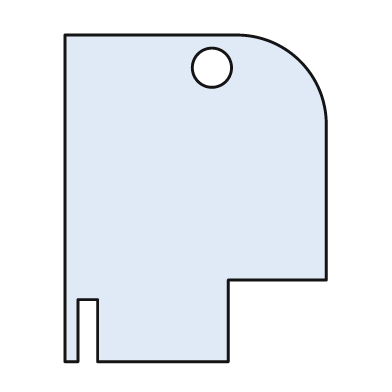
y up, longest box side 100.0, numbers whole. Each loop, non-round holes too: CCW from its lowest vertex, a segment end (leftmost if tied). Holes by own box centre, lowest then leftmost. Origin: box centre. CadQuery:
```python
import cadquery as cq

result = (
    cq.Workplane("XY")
    .moveTo(-40.0, -50.0)
    .lineTo(-36.0, -50.0)
    .lineTo(-36.0, -31.0)
    .lineTo(-30.0, -31.0)
    .lineTo(-30.0, -50.0)
    .lineTo(10.0, -50.0)
    .lineTo(10.0, -25.0)
    .lineTo(40.0, -25.0)
    .lineTo(40.0, 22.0)
    .threePointArc((32.0, 42.0), (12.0, 50.0))
    .lineTo(-40.0, 50.0)
    .close()
    .moveTo(5.0, 40.0)
    .circle(6.0)
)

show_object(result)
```